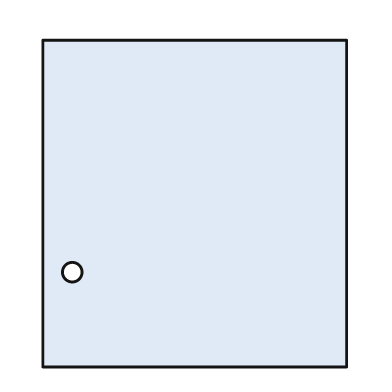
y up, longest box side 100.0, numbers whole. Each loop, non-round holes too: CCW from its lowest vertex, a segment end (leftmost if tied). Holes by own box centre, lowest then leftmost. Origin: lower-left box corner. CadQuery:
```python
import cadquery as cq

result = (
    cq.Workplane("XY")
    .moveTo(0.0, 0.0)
    .lineTo(93.0, 0.0)
    .lineTo(93.0, 100.0)
    .lineTo(0.0, 100.0)
    .close()
    .moveTo(9.0, 29.0)
    .circle(3.0)
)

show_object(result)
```